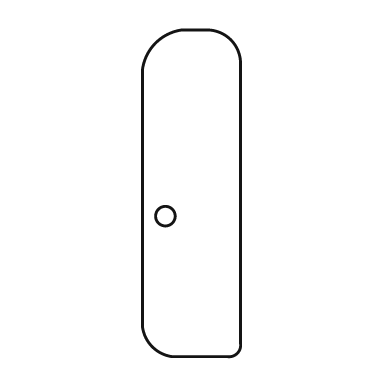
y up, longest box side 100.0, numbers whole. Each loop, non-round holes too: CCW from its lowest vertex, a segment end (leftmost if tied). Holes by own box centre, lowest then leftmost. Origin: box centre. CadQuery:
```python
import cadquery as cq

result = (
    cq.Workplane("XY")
    .moveTo(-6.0, -50.0)
    .lineTo(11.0, -50.0)
    .threePointArc((14.0, -49.0), (15.0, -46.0))
    .lineTo(15.0, 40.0)
    .threePointArc((12.0, 47.0), (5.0, 50.0))
    .lineTo(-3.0, 50.0)
    .threePointArc((-11.0, 46.0), (-15.0, 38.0))
    .lineTo(-15.0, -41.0)
    .threePointArc((-12.0, -47.0), (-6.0, -50.0))
    .close()
    .moveTo(-8.0, -7.0)
    .circle(3.0)
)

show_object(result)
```